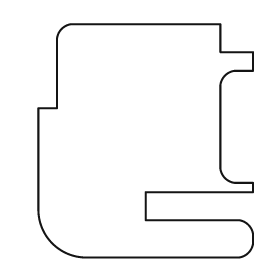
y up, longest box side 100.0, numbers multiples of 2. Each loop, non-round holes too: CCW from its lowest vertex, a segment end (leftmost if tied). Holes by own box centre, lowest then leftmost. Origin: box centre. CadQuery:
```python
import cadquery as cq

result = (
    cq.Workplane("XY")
    .moveTo(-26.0, -50.0)
    .lineTo(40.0, -50.0)
    .threePointArc((44.0, -48.0), (46.0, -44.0))
    .lineTo(46.0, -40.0)
    .threePointArc((44.0, -36.0), (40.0, -34.0))
    .lineTo(0.0, -34.0)
    .lineTo(0.0, -22.0)
    .lineTo(46.0, -22.0)
    .lineTo(46.0, -18.0)
    .lineTo(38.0, -18.0)
    .threePointArc((34.0, -16.0), (32.0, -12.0))
    .lineTo(32.0, 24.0)
    .threePointArc((34.0, 28.0), (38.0, 30.0))
    .lineTo(46.0, 30.0)
    .lineTo(46.0, 38.0)
    .lineTo(32.0, 38.0)
    .lineTo(32.0, 50.0)
    .lineTo(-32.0, 50.0)
    .threePointArc((-36.0, 48.0), (-38.0, 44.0))
    .lineTo(-38.0, 14.0)
    .lineTo(-46.0, 14.0)
    .lineTo(-46.0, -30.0)
    .threePointArc((-40.0, -44.0), (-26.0, -50.0))
    .close()
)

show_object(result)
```